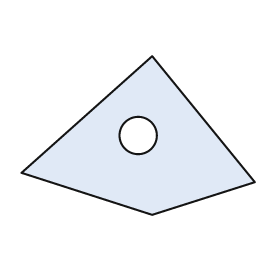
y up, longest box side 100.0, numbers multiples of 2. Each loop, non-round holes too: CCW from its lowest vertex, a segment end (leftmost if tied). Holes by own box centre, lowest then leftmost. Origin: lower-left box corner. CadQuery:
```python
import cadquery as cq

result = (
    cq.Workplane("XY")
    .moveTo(56.0, 0.0)
    .lineTo(100.0, 14.0)
    .lineTo(56.0, 68.0)
    .lineTo(0.0, 18.0)
    .close()
    .moveTo(50.0, 34.0)
    .circle(8.0)
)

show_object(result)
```